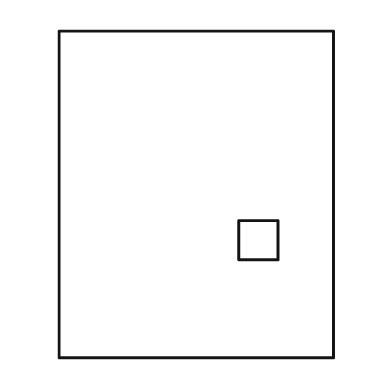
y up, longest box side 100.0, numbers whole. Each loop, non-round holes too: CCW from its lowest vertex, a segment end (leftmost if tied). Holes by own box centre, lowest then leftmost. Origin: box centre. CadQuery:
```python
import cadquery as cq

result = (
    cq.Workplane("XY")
    .moveTo(-42.0, -50.0)
    .lineTo(42.0, -50.0)
    .lineTo(42.0, 50.0)
    .lineTo(-42.0, 50.0)
    .close()
    .moveTo(13.0, -20.0)
    .lineTo(25.0, -20.0)
    .lineTo(25.0, -8.0)
    .lineTo(13.0, -8.0)
    .close()
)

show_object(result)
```